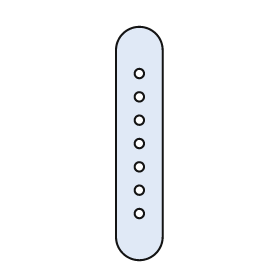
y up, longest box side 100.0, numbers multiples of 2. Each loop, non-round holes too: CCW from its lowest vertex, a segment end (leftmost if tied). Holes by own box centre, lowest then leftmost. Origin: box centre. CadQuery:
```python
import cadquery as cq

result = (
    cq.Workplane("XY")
    .moveTo(-10.0, -40.0)
    .threePointArc((0.0, -50.0), (10.0, -40.0))
    .lineTo(10.0, 40.0)
    .threePointArc((0.0, 50.0), (-10.0, 40.0))
    .close()
    .moveTo(0.0, -30.0)
    .circle(2.0)
    .moveTo(0.0, -20.0)
    .circle(2.0)
    .moveTo(0.0, -10.0)
    .circle(2.0)
    .moveTo(0.0, 0.0)
    .circle(2.0)
    .moveTo(0.0, 10.0)
    .circle(2.0)
    .moveTo(0.0, 20.0)
    .circle(2.0)
    .moveTo(0.0, 30.0)
    .circle(2.0)
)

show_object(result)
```